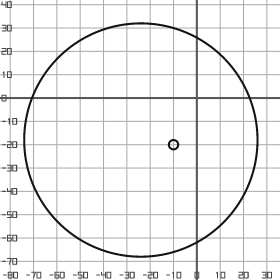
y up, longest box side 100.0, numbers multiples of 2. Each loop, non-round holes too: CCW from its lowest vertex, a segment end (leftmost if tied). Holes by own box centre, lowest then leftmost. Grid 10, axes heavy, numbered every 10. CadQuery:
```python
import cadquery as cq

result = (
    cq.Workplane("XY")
    .moveTo(-24.0, -18.0)
    .circle(50.0)
    .moveTo(-10.0, -20.0)
    .circle(2.0)
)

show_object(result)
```